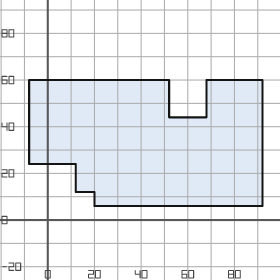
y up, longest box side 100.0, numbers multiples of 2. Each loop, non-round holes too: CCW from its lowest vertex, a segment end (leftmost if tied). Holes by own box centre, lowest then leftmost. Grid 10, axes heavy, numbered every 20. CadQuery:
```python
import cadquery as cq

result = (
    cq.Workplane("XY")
    .moveTo(20.0, 6.0)
    .lineTo(92.0, 6.0)
    .lineTo(92.0, 60.0)
    .lineTo(68.0, 60.0)
    .lineTo(68.0, 44.0)
    .lineTo(52.0, 44.0)
    .lineTo(52.0, 60.0)
    .lineTo(-8.0, 60.0)
    .lineTo(-8.0, 24.0)
    .lineTo(12.0, 24.0)
    .lineTo(12.0, 12.0)
    .lineTo(20.0, 12.0)
    .close()
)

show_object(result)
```